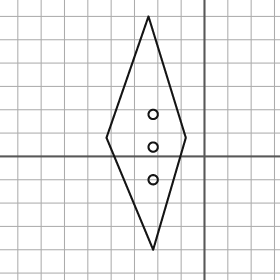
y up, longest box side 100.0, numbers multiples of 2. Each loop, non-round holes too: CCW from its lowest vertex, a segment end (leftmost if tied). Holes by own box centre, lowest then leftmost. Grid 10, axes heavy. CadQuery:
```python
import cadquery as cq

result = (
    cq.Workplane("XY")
    .moveTo(-22.0, -40.0)
    .lineTo(-8.0, 8.0)
    .lineTo(-24.0, 60.0)
    .lineTo(-42.0, 8.0)
    .close()
    .moveTo(-22.0, -10.0)
    .circle(2.0)
    .moveTo(-22.0, 4.0)
    .circle(2.0)
    .moveTo(-22.0, 18.0)
    .circle(2.0)
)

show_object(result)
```